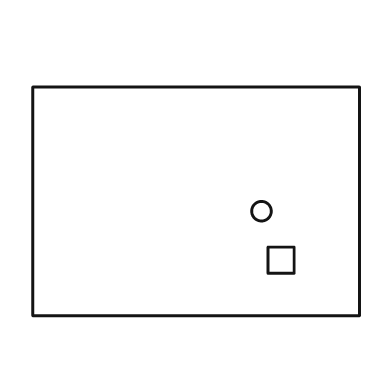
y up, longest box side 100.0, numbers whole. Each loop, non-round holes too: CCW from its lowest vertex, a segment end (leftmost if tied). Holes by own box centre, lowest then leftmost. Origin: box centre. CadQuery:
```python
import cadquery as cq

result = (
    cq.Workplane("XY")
    .moveTo(-50.0, -35.0)
    .lineTo(50.0, -35.0)
    .lineTo(50.0, 35.0)
    .lineTo(-50.0, 35.0)
    .close()
    .moveTo(22.0, -22.0)
    .lineTo(30.0, -22.0)
    .lineTo(30.0, -14.0)
    .lineTo(22.0, -14.0)
    .close()
    .moveTo(20.0, -3.0)
    .circle(3.0)
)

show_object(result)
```